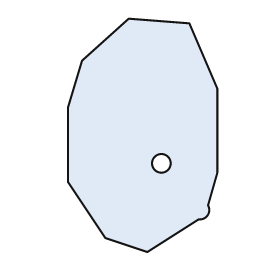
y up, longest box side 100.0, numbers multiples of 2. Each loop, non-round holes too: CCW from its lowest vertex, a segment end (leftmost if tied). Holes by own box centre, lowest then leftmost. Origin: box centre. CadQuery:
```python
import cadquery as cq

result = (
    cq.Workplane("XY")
    .moveTo(2.0, -50.0)
    .lineTo(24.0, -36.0)
    .threePointArc((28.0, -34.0), (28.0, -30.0))
    .lineTo(32.0, -16.0)
    .lineTo(32.0, 20.0)
    .lineTo(20.0, 48.0)
    .lineTo(-6.0, 50.0)
    .lineTo(-26.0, 32.0)
    .lineTo(-32.0, 12.0)
    .lineTo(-32.0, -20.0)
    .lineTo(-16.0, -44.0)
    .close()
    .moveTo(8.0, -12.0)
    .circle(4.0)
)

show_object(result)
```